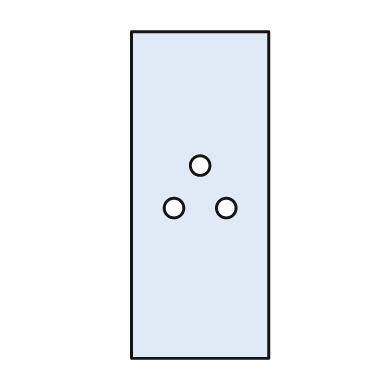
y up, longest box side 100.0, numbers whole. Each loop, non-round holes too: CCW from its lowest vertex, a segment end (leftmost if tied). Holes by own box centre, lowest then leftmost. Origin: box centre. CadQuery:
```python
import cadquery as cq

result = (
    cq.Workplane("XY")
    .moveTo(-21.0, -50.0)
    .lineTo(21.0, -50.0)
    .lineTo(21.0, 50.0)
    .lineTo(-21.0, 50.0)
    .close()
    .moveTo(-8.0, -4.0)
    .circle(3.0)
    .moveTo(8.0, -4.0)
    .circle(3.0)
    .moveTo(0.0, 9.0)
    .circle(3.0)
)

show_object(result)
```